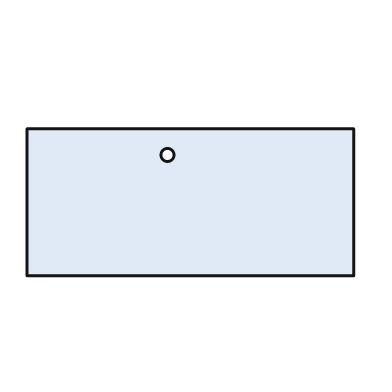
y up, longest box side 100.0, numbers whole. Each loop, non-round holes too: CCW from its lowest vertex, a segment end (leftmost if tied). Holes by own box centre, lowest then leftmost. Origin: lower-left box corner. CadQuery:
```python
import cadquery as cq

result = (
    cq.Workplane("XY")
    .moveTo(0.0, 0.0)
    .lineTo(100.0, 0.0)
    .lineTo(100.0, 45.0)
    .lineTo(0.0, 45.0)
    .close()
    .moveTo(43.0, 37.0)
    .circle(2.0)
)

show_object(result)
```